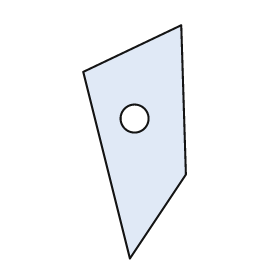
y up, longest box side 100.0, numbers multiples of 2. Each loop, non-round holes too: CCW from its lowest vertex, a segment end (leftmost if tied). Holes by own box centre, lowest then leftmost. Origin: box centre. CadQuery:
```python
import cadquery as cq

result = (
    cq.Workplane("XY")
    .moveTo(-2.0, -50.0)
    .lineTo(22.0, -14.0)
    .lineTo(20.0, 50.0)
    .lineTo(-22.0, 30.0)
    .close()
    .moveTo(0.0, 10.0)
    .circle(6.0)
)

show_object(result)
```